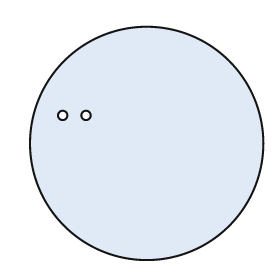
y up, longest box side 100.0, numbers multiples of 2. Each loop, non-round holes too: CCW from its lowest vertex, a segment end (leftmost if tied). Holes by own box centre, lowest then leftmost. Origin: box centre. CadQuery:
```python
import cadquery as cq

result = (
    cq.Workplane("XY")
    .moveTo(0.0, 0.0)
    .circle(50.0)
    .moveTo(-36.0, 12.0)
    .circle(2.0)
    .moveTo(-26.0, 12.0)
    .circle(2.0)
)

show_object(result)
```